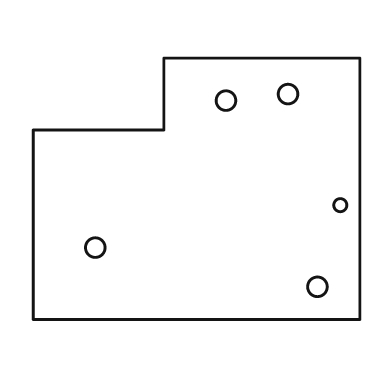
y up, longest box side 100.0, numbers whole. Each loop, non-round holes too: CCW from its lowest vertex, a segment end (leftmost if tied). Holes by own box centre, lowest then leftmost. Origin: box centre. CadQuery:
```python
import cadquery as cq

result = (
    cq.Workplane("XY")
    .moveTo(-50.0, -40.0)
    .lineTo(50.0, -40.0)
    .lineTo(50.0, 40.0)
    .lineTo(-10.0, 40.0)
    .lineTo(-10.0, 18.0)
    .lineTo(-50.0, 18.0)
    .close()
    .moveTo(37.0, -30.0)
    .circle(3.0)
    .moveTo(-31.0, -18.0)
    .circle(3.0)
    .moveTo(44.0, -5.0)
    .circle(2.0)
    .moveTo(9.0, 27.0)
    .circle(3.0)
    .moveTo(28.0, 29.0)
    .circle(3.0)
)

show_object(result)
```